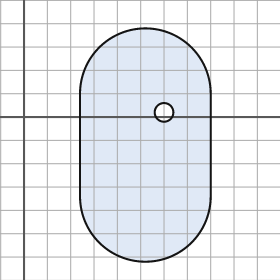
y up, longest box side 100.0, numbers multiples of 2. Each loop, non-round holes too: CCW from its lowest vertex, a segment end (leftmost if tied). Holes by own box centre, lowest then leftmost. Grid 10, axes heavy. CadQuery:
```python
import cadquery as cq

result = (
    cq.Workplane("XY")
    .moveTo(24.0, -34.0)
    .threePointArc((52.0, -62.0), (80.0, -34.0))
    .lineTo(80.0, 10.0)
    .threePointArc((52.0, 38.0), (24.0, 10.0))
    .close()
    .moveTo(60.0, 2.0)
    .circle(4.0)
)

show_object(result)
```